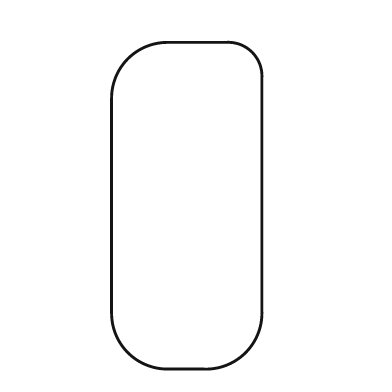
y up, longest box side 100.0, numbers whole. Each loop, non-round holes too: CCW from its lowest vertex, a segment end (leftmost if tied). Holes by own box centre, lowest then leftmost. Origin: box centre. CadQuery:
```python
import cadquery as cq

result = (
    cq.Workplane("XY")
    .moveTo(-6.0, -50.0)
    .lineTo(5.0, -50.0)
    .threePointArc((18.0, -45.0), (23.0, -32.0))
    .lineTo(23.0, 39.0)
    .threePointArc((20.0, 47.0), (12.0, 50.0))
    .lineTo(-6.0, 50.0)
    .threePointArc((-18.0, 45.0), (-23.0, 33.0))
    .lineTo(-23.0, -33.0)
    .threePointArc((-18.0, -45.0), (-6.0, -50.0))
    .close()
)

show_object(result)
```